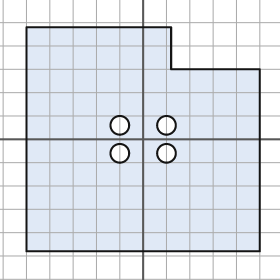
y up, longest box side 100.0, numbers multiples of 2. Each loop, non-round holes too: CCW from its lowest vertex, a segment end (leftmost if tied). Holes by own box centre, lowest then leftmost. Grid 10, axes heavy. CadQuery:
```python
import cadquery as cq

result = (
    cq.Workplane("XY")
    .moveTo(-50.0, -48.0)
    .lineTo(50.0, -48.0)
    .lineTo(50.0, 30.0)
    .lineTo(12.0, 30.0)
    .lineTo(12.0, 48.0)
    .lineTo(-50.0, 48.0)
    .close()
    .moveTo(-10.0, -6.0)
    .circle(4.0)
    .moveTo(10.0, -6.0)
    .circle(4.0)
    .moveTo(-10.0, 6.0)
    .circle(4.0)
    .moveTo(10.0, 6.0)
    .circle(4.0)
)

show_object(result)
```